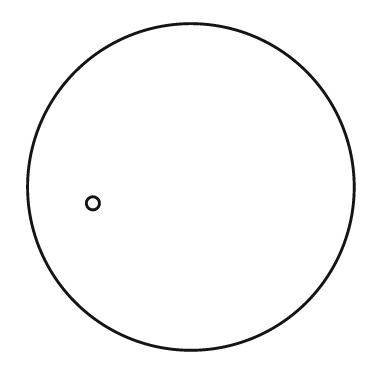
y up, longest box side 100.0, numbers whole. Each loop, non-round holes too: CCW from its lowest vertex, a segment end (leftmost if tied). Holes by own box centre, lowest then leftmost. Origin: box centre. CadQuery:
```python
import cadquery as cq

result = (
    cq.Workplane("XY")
    .moveTo(0.0, 0.0)
    .circle(50.0)
    .moveTo(-30.0, -5.0)
    .circle(2.0)
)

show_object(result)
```